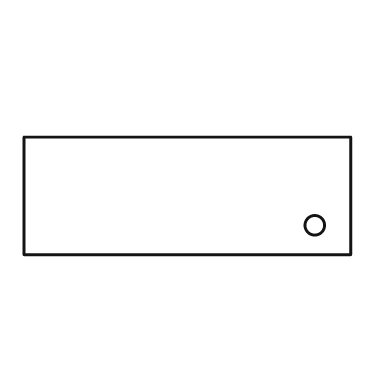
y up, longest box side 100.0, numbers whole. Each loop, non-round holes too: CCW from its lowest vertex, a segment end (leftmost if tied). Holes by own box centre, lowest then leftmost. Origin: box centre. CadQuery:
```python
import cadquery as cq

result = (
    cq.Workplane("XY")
    .moveTo(-50.0, -18.0)
    .lineTo(50.0, -18.0)
    .lineTo(50.0, 18.0)
    .lineTo(-50.0, 18.0)
    .close()
    .moveTo(39.0, -9.0)
    .circle(3.0)
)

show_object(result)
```